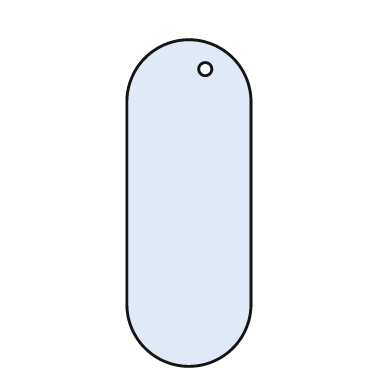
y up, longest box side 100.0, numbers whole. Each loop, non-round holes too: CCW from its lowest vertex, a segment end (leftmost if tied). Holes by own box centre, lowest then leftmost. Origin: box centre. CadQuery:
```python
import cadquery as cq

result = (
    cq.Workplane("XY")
    .moveTo(-19.0, -31.0)
    .threePointArc((0.0, -50.0), (19.0, -31.0))
    .lineTo(19.0, 31.0)
    .threePointArc((0.0, 50.0), (-19.0, 31.0))
    .close()
    .moveTo(5.0, 41.0)
    .circle(2.0)
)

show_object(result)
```